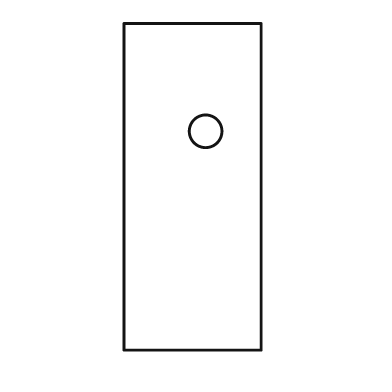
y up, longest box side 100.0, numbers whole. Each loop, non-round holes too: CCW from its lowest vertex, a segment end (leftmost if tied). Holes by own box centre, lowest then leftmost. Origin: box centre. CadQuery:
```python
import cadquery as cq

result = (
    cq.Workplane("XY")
    .moveTo(-21.0, -50.0)
    .lineTo(21.0, -50.0)
    .lineTo(21.0, 50.0)
    .lineTo(-21.0, 50.0)
    .close()
    .moveTo(4.0, 17.0)
    .circle(5.0)
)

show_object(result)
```